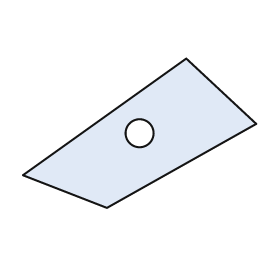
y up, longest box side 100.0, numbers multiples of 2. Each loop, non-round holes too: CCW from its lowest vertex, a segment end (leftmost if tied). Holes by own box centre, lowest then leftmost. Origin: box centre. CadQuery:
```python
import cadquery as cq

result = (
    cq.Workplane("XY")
    .moveTo(-14.0, -32.0)
    .lineTo(50.0, 4.0)
    .lineTo(20.0, 32.0)
    .lineTo(-50.0, -18.0)
    .close()
    .moveTo(0.0, 0.0)
    .circle(6.0)
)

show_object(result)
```